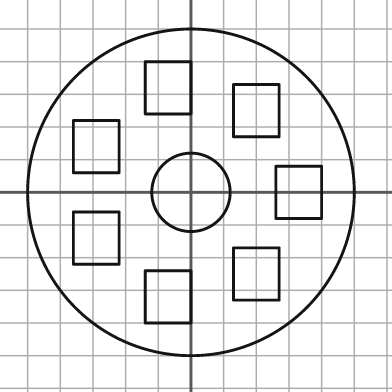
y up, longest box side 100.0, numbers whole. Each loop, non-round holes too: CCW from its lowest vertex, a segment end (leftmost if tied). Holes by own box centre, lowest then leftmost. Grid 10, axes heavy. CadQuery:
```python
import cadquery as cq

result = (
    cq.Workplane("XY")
    .moveTo(0.0, 0.0)
    .circle(50.0)
    .moveTo(-14.0, -40.0)
    .lineTo(0.0, -40.0)
    .lineTo(0.0, -24.0)
    .lineTo(-14.0, -24.0)
    .close()
    .moveTo(13.0, -33.0)
    .lineTo(27.0, -33.0)
    .lineTo(27.0, -17.0)
    .lineTo(13.0, -17.0)
    .close()
    .moveTo(-36.0, -22.0)
    .lineTo(-22.0, -22.0)
    .lineTo(-22.0, -6.0)
    .lineTo(-36.0, -6.0)
    .close()
    .moveTo(0.0, 0.0)
    .circle(12.0)
    .moveTo(26.0, -8.0)
    .lineTo(40.0, -8.0)
    .lineTo(40.0, 8.0)
    .lineTo(26.0, 8.0)
    .close()
    .moveTo(-36.0, 6.0)
    .lineTo(-22.0, 6.0)
    .lineTo(-22.0, 22.0)
    .lineTo(-36.0, 22.0)
    .close()
    .moveTo(13.0, 17.0)
    .lineTo(27.0, 17.0)
    .lineTo(27.0, 33.0)
    .lineTo(13.0, 33.0)
    .close()
    .moveTo(-14.0, 24.0)
    .lineTo(0.0, 24.0)
    .lineTo(0.0, 40.0)
    .lineTo(-14.0, 40.0)
    .close()
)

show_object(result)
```